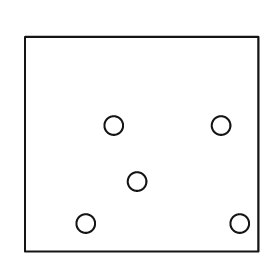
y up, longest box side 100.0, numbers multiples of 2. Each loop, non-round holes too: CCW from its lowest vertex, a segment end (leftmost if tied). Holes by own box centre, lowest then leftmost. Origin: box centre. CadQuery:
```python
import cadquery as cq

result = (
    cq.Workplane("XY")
    .moveTo(-50.0, -46.0)
    .lineTo(50.0, -46.0)
    .lineTo(50.0, 46.0)
    .lineTo(-50.0, 46.0)
    .close()
    .moveTo(-24.0, -34.0)
    .circle(4.0)
    .moveTo(42.0, -34.0)
    .circle(4.0)
    .moveTo(-2.0, -16.0)
    .circle(4.0)
    .moveTo(-12.0, 8.0)
    .circle(4.0)
    .moveTo(34.0, 8.0)
    .circle(4.0)
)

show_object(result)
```